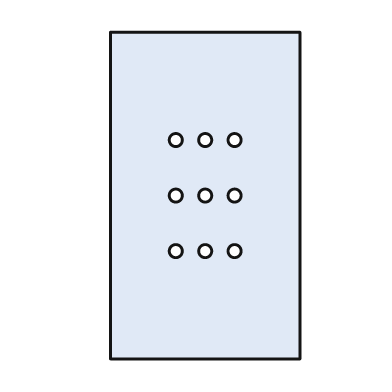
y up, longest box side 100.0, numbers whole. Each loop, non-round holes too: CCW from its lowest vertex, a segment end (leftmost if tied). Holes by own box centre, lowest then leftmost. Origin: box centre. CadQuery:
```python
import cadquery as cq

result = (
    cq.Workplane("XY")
    .moveTo(-29.0, -50.0)
    .lineTo(29.0, -50.0)
    .lineTo(29.0, 50.0)
    .lineTo(-29.0, 50.0)
    .close()
    .moveTo(-9.0, -17.0)
    .circle(2.0)
    .moveTo(0.0, -17.0)
    .circle(2.0)
    .moveTo(9.0, -17.0)
    .circle(2.0)
    .moveTo(-9.0, 0.0)
    .circle(2.0)
    .moveTo(0.0, 0.0)
    .circle(2.0)
    .moveTo(9.0, 0.0)
    .circle(2.0)
    .moveTo(-9.0, 17.0)
    .circle(2.0)
    .moveTo(0.0, 17.0)
    .circle(2.0)
    .moveTo(9.0, 17.0)
    .circle(2.0)
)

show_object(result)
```